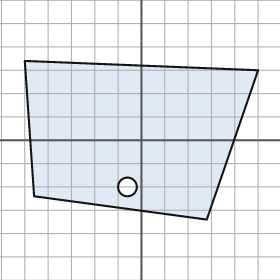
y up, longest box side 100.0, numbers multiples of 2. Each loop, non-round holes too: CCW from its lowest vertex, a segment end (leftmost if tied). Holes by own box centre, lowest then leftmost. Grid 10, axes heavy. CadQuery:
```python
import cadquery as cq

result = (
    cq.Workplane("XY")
    .moveTo(28.0, -34.0)
    .lineTo(50.0, 30.0)
    .lineTo(-50.0, 34.0)
    .lineTo(-46.0, -24.0)
    .close()
    .moveTo(-6.0, -20.0)
    .circle(4.0)
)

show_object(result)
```